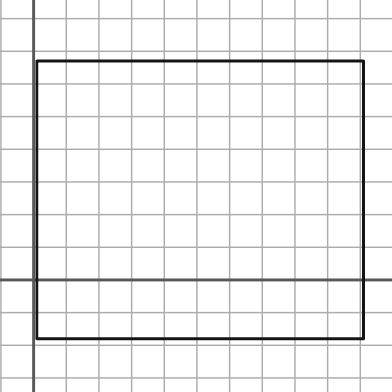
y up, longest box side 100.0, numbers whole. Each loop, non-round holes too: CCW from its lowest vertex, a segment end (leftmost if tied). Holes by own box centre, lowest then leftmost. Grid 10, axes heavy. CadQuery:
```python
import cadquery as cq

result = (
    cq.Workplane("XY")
    .moveTo(1.0, -18.0)
    .lineTo(101.0, -18.0)
    .lineTo(101.0, 67.0)
    .lineTo(1.0, 67.0)
    .close()
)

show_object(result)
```